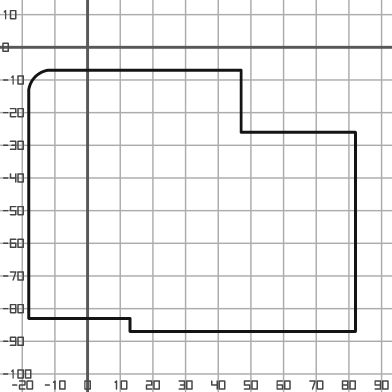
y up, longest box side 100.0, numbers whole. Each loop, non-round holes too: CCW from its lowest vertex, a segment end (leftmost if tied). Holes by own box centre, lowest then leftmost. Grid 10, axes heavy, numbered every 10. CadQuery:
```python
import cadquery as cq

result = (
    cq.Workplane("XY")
    .moveTo(13.0, -87.0)
    .lineTo(82.0, -87.0)
    .lineTo(82.0, -26.0)
    .lineTo(47.0, -26.0)
    .lineTo(47.0, -7.0)
    .lineTo(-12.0, -7.0)
    .threePointArc((-16.0, -9.0), (-18.0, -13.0))
    .lineTo(-18.0, -83.0)
    .lineTo(13.0, -83.0)
    .close()
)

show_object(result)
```